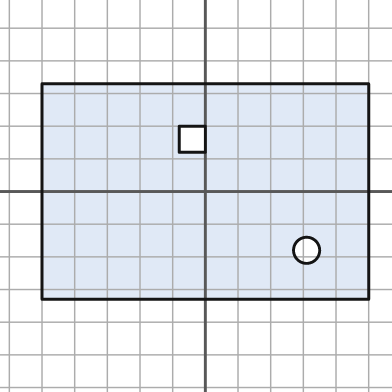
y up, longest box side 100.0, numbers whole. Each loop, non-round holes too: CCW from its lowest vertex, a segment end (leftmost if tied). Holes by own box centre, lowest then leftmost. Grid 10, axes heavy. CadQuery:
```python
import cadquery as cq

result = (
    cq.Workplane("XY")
    .moveTo(-50.0, -33.0)
    .lineTo(50.0, -33.0)
    .lineTo(50.0, 33.0)
    .lineTo(-50.0, 33.0)
    .close()
    .moveTo(31.0, -18.0)
    .circle(4.0)
    .moveTo(-8.0, 12.0)
    .lineTo(0.0, 12.0)
    .lineTo(0.0, 20.0)
    .lineTo(-8.0, 20.0)
    .close()
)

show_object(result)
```